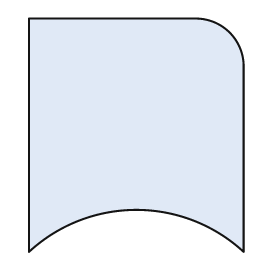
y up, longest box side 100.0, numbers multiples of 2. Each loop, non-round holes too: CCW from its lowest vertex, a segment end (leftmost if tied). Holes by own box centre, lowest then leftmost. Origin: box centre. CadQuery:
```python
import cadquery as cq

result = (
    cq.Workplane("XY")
    .moveTo(-46.0, -50.0)
    .threePointArc((0.0, -32.0), (46.0, -50.0))
    .lineTo(46.0, 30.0)
    .threePointArc((40.0, 44.0), (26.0, 50.0))
    .lineTo(-46.0, 50.0)
    .close()
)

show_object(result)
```